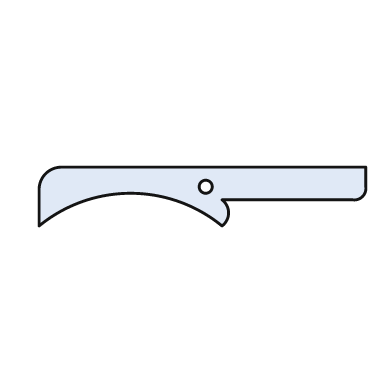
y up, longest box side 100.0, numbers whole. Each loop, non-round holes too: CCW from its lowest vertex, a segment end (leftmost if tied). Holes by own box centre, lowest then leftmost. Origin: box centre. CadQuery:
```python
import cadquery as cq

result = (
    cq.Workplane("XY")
    .moveTo(-50.0, -9.0)
    .threePointArc((-22.0, 1.0), (6.0, -9.0))
    .threePointArc((8.0, -5.0), (6.0, -1.0))
    .lineTo(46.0, -1.0)
    .threePointArc((49.0, 0.0), (50.0, 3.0))
    .lineTo(50.0, 9.0)
    .lineTo(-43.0, 9.0)
    .threePointArc((-48.0, 7.0), (-50.0, 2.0))
    .close()
    .moveTo(1.0, 3.0)
    .circle(2.0)
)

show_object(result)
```